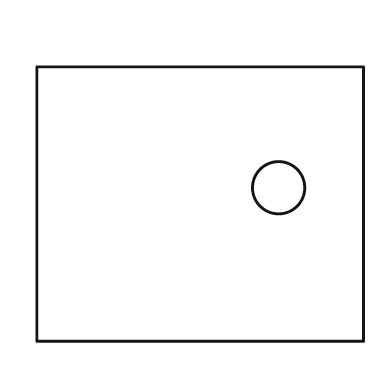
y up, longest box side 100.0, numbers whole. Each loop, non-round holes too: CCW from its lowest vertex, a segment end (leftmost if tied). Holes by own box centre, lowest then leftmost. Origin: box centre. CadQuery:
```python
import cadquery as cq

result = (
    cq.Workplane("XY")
    .moveTo(-50.0, -42.0)
    .lineTo(50.0, -42.0)
    .lineTo(50.0, 42.0)
    .lineTo(-50.0, 42.0)
    .close()
    .moveTo(24.0, 5.0)
    .circle(8.0)
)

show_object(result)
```